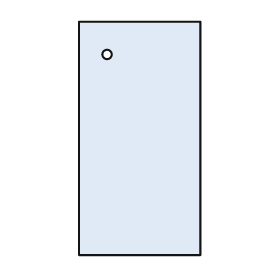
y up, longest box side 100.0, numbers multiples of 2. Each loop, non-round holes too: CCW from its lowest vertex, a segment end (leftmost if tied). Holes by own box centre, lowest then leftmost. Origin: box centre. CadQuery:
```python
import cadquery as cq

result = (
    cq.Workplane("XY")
    .moveTo(-26.0, -50.0)
    .lineTo(26.0, -50.0)
    .lineTo(26.0, 50.0)
    .lineTo(-26.0, 50.0)
    .close()
    .moveTo(-14.0, 36.0)
    .circle(2.0)
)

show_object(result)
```